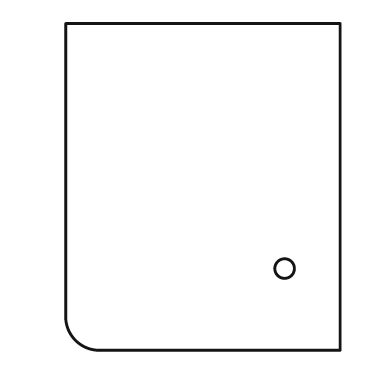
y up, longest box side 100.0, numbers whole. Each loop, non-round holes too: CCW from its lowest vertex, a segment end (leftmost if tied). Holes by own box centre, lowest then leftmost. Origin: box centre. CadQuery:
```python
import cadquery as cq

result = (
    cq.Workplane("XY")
    .moveTo(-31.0, -50.0)
    .lineTo(42.0, -50.0)
    .lineTo(42.0, 50.0)
    .lineTo(-42.0, 50.0)
    .lineTo(-42.0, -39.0)
    .threePointArc((-39.0, -47.0), (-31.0, -50.0))
    .close()
    .moveTo(25.0, -25.0)
    .circle(3.0)
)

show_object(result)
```